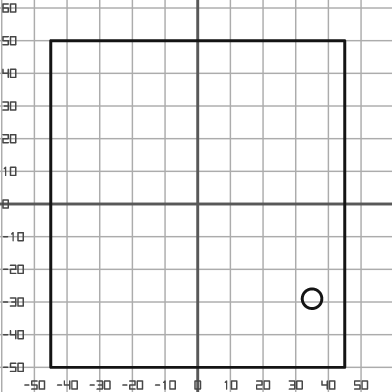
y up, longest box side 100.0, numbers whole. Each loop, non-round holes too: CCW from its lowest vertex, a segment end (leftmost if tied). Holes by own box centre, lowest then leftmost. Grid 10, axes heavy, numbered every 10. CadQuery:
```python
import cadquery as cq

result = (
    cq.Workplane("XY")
    .moveTo(-45.0, -50.0)
    .lineTo(45.0, -50.0)
    .lineTo(45.0, 50.0)
    .lineTo(-45.0, 50.0)
    .close()
    .moveTo(35.0, -29.0)
    .circle(3.0)
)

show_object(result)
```